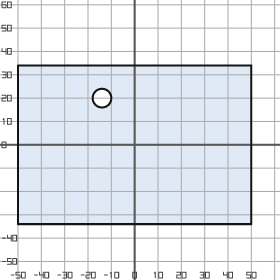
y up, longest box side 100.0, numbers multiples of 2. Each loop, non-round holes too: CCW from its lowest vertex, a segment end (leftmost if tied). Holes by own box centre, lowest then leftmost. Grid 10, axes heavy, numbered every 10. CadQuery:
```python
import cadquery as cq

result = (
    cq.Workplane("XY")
    .moveTo(-50.0, -34.0)
    .lineTo(50.0, -34.0)
    .lineTo(50.0, 34.0)
    .lineTo(-50.0, 34.0)
    .close()
    .moveTo(-14.0, 20.0)
    .circle(4.0)
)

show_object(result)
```